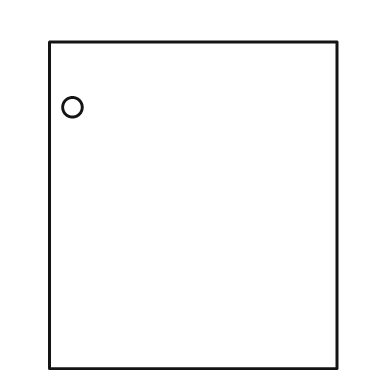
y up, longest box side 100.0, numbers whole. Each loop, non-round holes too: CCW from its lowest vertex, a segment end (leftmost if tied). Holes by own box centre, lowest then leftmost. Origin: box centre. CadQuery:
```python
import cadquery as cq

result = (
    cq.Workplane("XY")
    .moveTo(-44.0, -50.0)
    .lineTo(44.0, -50.0)
    .lineTo(44.0, 50.0)
    .lineTo(-44.0, 50.0)
    .close()
    .moveTo(-37.0, 30.0)
    .circle(3.0)
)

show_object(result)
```